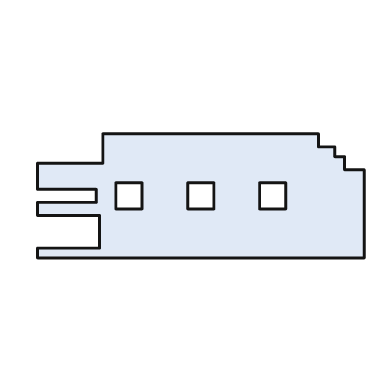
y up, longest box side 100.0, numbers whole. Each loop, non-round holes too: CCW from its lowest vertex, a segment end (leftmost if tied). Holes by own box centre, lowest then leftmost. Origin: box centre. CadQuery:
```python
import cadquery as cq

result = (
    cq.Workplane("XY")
    .moveTo(-50.0, -19.0)
    .lineTo(50.0, -19.0)
    .lineTo(50.0, 8.0)
    .lineTo(44.0, 8.0)
    .lineTo(44.0, 12.0)
    .lineTo(41.0, 12.0)
    .lineTo(41.0, 15.0)
    .lineTo(36.0, 15.0)
    .lineTo(36.0, 19.0)
    .lineTo(-30.0, 19.0)
    .lineTo(-30.0, 10.0)
    .lineTo(-50.0, 10.0)
    .lineTo(-50.0, 2.0)
    .lineTo(-32.0, 2.0)
    .lineTo(-32.0, -2.0)
    .lineTo(-50.0, -2.0)
    .lineTo(-50.0, -6.0)
    .lineTo(-31.0, -6.0)
    .lineTo(-31.0, -16.0)
    .lineTo(-50.0, -16.0)
    .close()
    .moveTo(-26.0, -4.0)
    .lineTo(-18.0, -4.0)
    .lineTo(-18.0, 4.0)
    .lineTo(-26.0, 4.0)
    .close()
    .moveTo(-4.0, -4.0)
    .lineTo(4.0, -4.0)
    .lineTo(4.0, 4.0)
    .lineTo(-4.0, 4.0)
    .close()
    .moveTo(18.0, -4.0)
    .lineTo(26.0, -4.0)
    .lineTo(26.0, 4.0)
    .lineTo(18.0, 4.0)
    .close()
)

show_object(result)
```